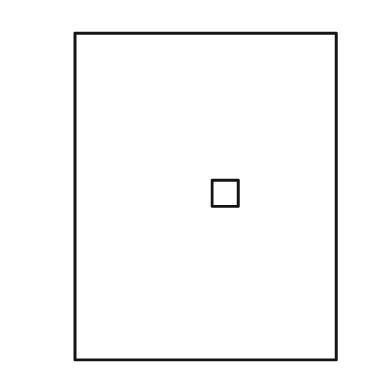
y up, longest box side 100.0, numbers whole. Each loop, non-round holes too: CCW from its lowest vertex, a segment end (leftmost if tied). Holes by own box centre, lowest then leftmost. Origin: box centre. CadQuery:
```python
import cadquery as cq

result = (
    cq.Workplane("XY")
    .moveTo(-40.0, -50.0)
    .lineTo(40.0, -50.0)
    .lineTo(40.0, 50.0)
    .lineTo(-40.0, 50.0)
    .close()
    .moveTo(2.0, -3.0)
    .lineTo(10.0, -3.0)
    .lineTo(10.0, 5.0)
    .lineTo(2.0, 5.0)
    .close()
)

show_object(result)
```